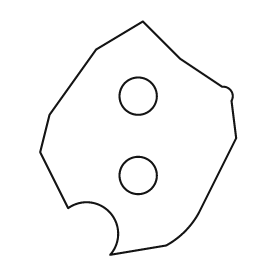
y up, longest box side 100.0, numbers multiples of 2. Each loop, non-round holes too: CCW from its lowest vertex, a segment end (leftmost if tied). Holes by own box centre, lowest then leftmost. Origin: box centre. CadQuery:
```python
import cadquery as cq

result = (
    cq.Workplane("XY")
    .moveTo(-12.0, -50.0)
    .lineTo(12.0, -46.0)
    .threePointArc((20.0, -40.0), (26.0, -32.0))
    .lineTo(42.0, 0.0)
    .lineTo(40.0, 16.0)
    .threePointArc((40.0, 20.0), (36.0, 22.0))
    .lineTo(18.0, 34.0)
    .lineTo(2.0, 50.0)
    .lineTo(-18.0, 38.0)
    .lineTo(-38.0, 10.0)
    .lineTo(-42.0, -6.0)
    .lineTo(-30.0, -30.0)
    .threePointArc((-12.0, -32.0), (-12.0, -50.0))
    .close()
    .moveTo(0.0, -16.0)
    .circle(8.0)
    .moveTo(0.0, 18.0)
    .circle(8.0)
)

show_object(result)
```